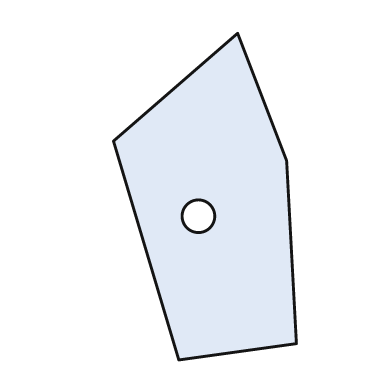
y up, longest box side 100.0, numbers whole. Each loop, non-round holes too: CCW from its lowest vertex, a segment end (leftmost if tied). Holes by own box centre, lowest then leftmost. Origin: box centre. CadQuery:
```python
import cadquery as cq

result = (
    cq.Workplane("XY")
    .moveTo(-8.0, -50.0)
    .lineTo(28.0, -45.0)
    .lineTo(25.0, 11.0)
    .lineTo(10.0, 50.0)
    .lineTo(-28.0, 17.0)
    .close()
    .moveTo(-2.0, -6.0)
    .circle(5.0)
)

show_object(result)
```